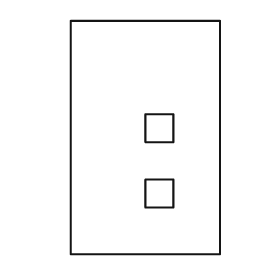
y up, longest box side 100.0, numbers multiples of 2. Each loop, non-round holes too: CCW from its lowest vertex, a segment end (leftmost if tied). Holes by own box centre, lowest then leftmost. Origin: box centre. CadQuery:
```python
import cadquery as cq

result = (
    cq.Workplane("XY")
    .moveTo(-32.0, -50.0)
    .lineTo(32.0, -50.0)
    .lineTo(32.0, 50.0)
    .lineTo(-32.0, 50.0)
    .close()
    .moveTo(0.0, -30.0)
    .lineTo(12.0, -30.0)
    .lineTo(12.0, -18.0)
    .lineTo(0.0, -18.0)
    .close()
    .moveTo(0.0, -2.0)
    .lineTo(12.0, -2.0)
    .lineTo(12.0, 10.0)
    .lineTo(0.0, 10.0)
    .close()
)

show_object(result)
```